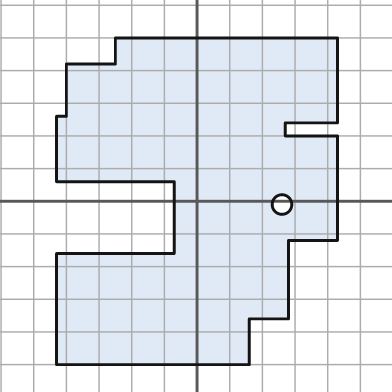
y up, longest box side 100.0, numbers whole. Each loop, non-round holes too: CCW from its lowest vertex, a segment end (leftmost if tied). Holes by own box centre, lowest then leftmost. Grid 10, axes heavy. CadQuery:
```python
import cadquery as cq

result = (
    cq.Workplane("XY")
    .moveTo(-43.0, -50.0)
    .lineTo(16.0, -50.0)
    .lineTo(16.0, -36.0)
    .lineTo(28.0, -36.0)
    .lineTo(28.0, -12.0)
    .lineTo(43.0, -12.0)
    .lineTo(43.0, 20.0)
    .lineTo(27.0, 20.0)
    .lineTo(27.0, 24.0)
    .lineTo(43.0, 24.0)
    .lineTo(43.0, 50.0)
    .lineTo(-25.0, 50.0)
    .lineTo(-25.0, 42.0)
    .lineTo(-40.0, 42.0)
    .lineTo(-40.0, 26.0)
    .lineTo(-43.0, 26.0)
    .lineTo(-43.0, 6.0)
    .lineTo(-7.0, 6.0)
    .lineTo(-7.0, -16.0)
    .lineTo(-43.0, -16.0)
    .close()
    .moveTo(26.0, -1.0)
    .circle(3.0)
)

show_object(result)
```